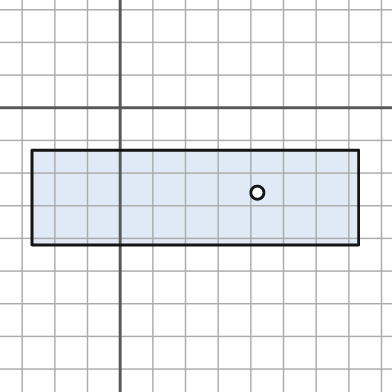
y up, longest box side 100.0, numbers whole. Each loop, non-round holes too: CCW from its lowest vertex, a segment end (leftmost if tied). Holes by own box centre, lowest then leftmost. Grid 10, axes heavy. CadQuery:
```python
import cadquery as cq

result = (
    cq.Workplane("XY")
    .moveTo(-27.0, -42.0)
    .lineTo(73.0, -42.0)
    .lineTo(73.0, -13.0)
    .lineTo(-27.0, -13.0)
    .close()
    .moveTo(42.0, -26.0)
    .circle(2.0)
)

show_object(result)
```